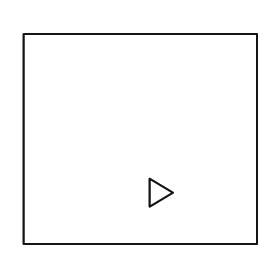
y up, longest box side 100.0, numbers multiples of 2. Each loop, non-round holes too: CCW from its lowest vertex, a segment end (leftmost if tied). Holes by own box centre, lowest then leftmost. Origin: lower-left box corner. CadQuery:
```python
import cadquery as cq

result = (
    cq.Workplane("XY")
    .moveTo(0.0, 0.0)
    .lineTo(100.0, 0.0)
    .lineTo(100.0, 90.0)
    .lineTo(0.0, 90.0)
    .close()
    .moveTo(54.0, 16.0)
    .lineTo(64.0, 22.0)
    .lineTo(54.0, 28.0)
    .close()
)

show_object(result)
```